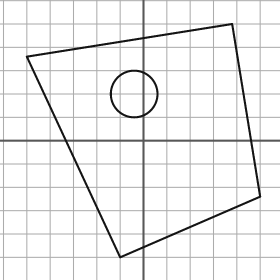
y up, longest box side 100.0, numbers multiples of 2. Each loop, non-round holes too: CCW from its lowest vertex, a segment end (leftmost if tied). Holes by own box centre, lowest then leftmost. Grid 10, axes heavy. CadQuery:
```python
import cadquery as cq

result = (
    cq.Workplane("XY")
    .moveTo(-10.0, -50.0)
    .lineTo(50.0, -24.0)
    .lineTo(38.0, 50.0)
    .lineTo(-50.0, 36.0)
    .close()
    .moveTo(-4.0, 20.0)
    .circle(10.0)
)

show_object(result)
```